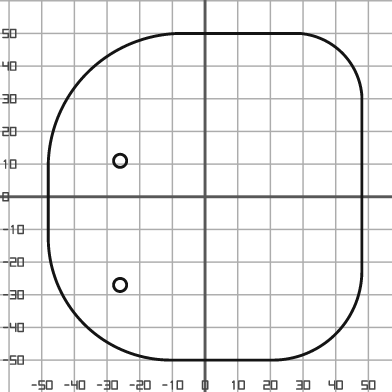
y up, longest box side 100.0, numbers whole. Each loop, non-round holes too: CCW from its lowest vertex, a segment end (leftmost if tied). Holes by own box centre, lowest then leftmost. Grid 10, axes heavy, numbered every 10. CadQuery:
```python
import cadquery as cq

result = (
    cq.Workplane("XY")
    .moveTo(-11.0, -50.0)
    .lineTo(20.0, -50.0)
    .threePointArc((40.0, -42.0), (48.0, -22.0))
    .lineTo(48.0, 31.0)
    .threePointArc((42.0, 44.0), (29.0, 50.0))
    .lineTo(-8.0, 50.0)
    .threePointArc((-36.0, 38.0), (-48.0, 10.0))
    .lineTo(-48.0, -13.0)
    .threePointArc((-37.0, -39.0), (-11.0, -50.0))
    .close()
    .moveTo(-26.0, -27.0)
    .circle(2.0)
    .moveTo(-26.0, 11.0)
    .circle(2.0)
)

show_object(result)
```